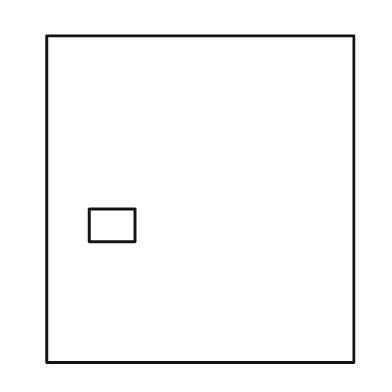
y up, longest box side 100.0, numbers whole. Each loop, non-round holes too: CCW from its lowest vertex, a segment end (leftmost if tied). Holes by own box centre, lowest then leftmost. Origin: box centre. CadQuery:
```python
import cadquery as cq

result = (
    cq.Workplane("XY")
    .moveTo(-47.0, -50.0)
    .lineTo(47.0, -50.0)
    .lineTo(47.0, 50.0)
    .lineTo(-47.0, 50.0)
    .close()
    .moveTo(-34.0, -13.0)
    .lineTo(-20.0, -13.0)
    .lineTo(-20.0, -3.0)
    .lineTo(-34.0, -3.0)
    .close()
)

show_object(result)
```